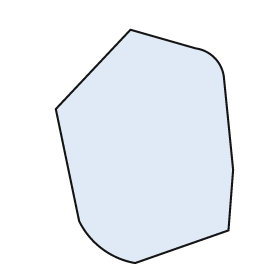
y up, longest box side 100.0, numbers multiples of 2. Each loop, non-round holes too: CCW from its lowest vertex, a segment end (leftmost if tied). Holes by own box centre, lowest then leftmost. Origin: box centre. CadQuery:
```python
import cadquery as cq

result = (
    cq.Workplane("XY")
    .moveTo(-4.0, -50.0)
    .lineTo(36.0, -36.0)
    .lineTo(38.0, -10.0)
    .lineTo(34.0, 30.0)
    .threePointArc((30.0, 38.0), (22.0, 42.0))
    .lineTo(-6.0, 50.0)
    .lineTo(-38.0, 16.0)
    .lineTo(-28.0, -32.0)
    .threePointArc((-18.0, -44.0), (-4.0, -50.0))
    .close()
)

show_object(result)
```